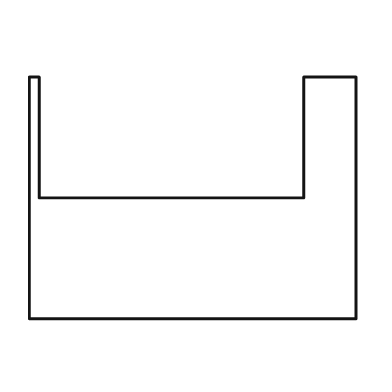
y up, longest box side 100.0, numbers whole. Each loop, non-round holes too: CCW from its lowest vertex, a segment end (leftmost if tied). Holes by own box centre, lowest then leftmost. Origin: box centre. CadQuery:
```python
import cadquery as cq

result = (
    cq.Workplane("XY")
    .moveTo(-50.0, -37.0)
    .lineTo(50.0, -37.0)
    .lineTo(50.0, 37.0)
    .lineTo(34.0, 37.0)
    .lineTo(34.0, 0.0)
    .lineTo(-47.0, 0.0)
    .lineTo(-47.0, 37.0)
    .lineTo(-50.0, 37.0)
    .close()
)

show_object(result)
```